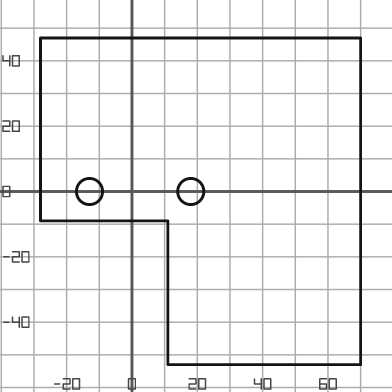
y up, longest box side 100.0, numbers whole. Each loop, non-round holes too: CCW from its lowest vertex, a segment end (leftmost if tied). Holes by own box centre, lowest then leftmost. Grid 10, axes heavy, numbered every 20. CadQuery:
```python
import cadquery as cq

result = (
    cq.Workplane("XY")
    .moveTo(11.0, -53.0)
    .lineTo(70.0, -53.0)
    .lineTo(70.0, 47.0)
    .lineTo(-28.0, 47.0)
    .lineTo(-28.0, -9.0)
    .lineTo(11.0, -9.0)
    .close()
    .moveTo(-13.0, 0.0)
    .circle(4.0)
    .moveTo(18.0, 0.0)
    .circle(4.0)
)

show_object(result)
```